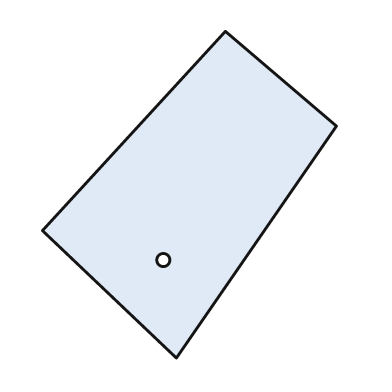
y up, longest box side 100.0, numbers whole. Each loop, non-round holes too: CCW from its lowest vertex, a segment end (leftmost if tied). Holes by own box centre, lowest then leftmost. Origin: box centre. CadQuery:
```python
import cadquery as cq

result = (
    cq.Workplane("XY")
    .moveTo(-4.0, -50.0)
    .lineTo(45.0, 21.0)
    .lineTo(11.0, 50.0)
    .lineTo(-45.0, -11.0)
    .close()
    .moveTo(-8.0, -20.0)
    .circle(2.0)
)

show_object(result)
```